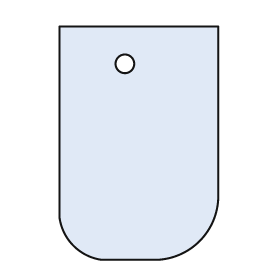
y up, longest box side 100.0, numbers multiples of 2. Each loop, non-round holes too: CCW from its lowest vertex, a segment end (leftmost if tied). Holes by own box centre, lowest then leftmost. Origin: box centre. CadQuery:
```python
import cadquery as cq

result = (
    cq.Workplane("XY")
    .moveTo(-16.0, -50.0)
    .lineTo(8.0, -50.0)
    .threePointArc((26.0, -42.0), (34.0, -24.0))
    .lineTo(34.0, 50.0)
    .lineTo(-34.0, 50.0)
    .lineTo(-34.0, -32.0)
    .threePointArc((-28.0, -44.0), (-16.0, -50.0))
    .close()
    .moveTo(-6.0, 34.0)
    .circle(4.0)
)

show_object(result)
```